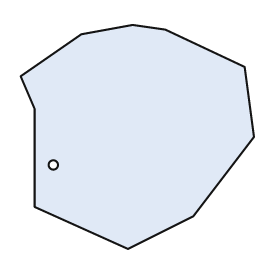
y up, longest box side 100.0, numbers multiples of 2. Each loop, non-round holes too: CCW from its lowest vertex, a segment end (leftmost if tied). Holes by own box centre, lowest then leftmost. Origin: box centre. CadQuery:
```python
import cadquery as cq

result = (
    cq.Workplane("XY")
    .moveTo(-4.0, -48.0)
    .lineTo(24.0, -34.0)
    .lineTo(50.0, 0.0)
    .lineTo(46.0, 30.0)
    .lineTo(12.0, 46.0)
    .lineTo(-2.0, 48.0)
    .lineTo(-24.0, 44.0)
    .lineTo(-50.0, 26.0)
    .lineTo(-44.0, 12.0)
    .lineTo(-44.0, -30.0)
    .close()
    .moveTo(-36.0, -12.0)
    .circle(2.0)
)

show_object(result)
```